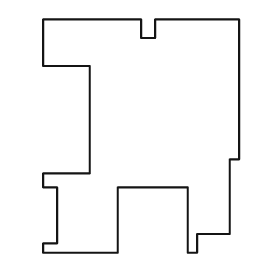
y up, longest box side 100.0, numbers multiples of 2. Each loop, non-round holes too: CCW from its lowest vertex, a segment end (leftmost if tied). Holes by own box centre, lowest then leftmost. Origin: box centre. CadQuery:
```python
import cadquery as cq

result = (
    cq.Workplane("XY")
    .moveTo(-42.0, -50.0)
    .lineTo(-10.0, -50.0)
    .lineTo(-10.0, -22.0)
    .lineTo(20.0, -22.0)
    .lineTo(20.0, -50.0)
    .lineTo(24.0, -50.0)
    .lineTo(24.0, -42.0)
    .lineTo(38.0, -42.0)
    .lineTo(38.0, -10.0)
    .lineTo(42.0, -10.0)
    .lineTo(42.0, 50.0)
    .lineTo(6.0, 50.0)
    .lineTo(6.0, 42.0)
    .lineTo(0.0, 42.0)
    .lineTo(0.0, 50.0)
    .lineTo(-42.0, 50.0)
    .lineTo(-42.0, 30.0)
    .lineTo(-22.0, 30.0)
    .lineTo(-22.0, -16.0)
    .lineTo(-42.0, -16.0)
    .lineTo(-42.0, -22.0)
    .lineTo(-36.0, -22.0)
    .lineTo(-36.0, -46.0)
    .lineTo(-42.0, -46.0)
    .close()
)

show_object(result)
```